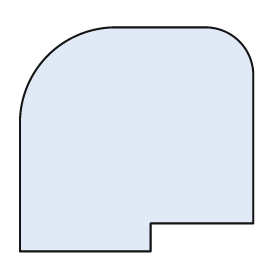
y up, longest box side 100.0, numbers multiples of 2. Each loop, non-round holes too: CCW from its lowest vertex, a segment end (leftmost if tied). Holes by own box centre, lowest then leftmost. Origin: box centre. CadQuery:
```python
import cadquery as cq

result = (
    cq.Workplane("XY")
    .moveTo(-50.0, -48.0)
    .lineTo(6.0, -48.0)
    .lineTo(6.0, -36.0)
    .lineTo(50.0, -36.0)
    .lineTo(50.0, 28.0)
    .threePointArc((44.0, 42.0), (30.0, 48.0))
    .lineTo(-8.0, 48.0)
    .threePointArc((-38.0, 36.0), (-50.0, 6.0))
    .close()
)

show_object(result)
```